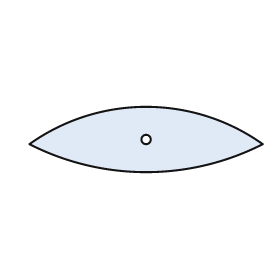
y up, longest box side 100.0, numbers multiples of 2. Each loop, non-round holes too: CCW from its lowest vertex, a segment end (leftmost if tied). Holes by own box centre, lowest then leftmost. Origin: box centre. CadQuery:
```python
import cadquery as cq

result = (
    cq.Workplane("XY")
    .moveTo(-50.0, -2.0)
    .threePointArc((0.0, -14.0), (50.0, -2.0))
    .threePointArc((0.0, 14.0), (-50.0, -2.0))
    .close()
    .moveTo(0.0, 0.0)
    .circle(2.0)
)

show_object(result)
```